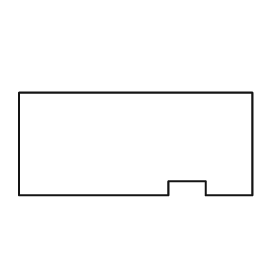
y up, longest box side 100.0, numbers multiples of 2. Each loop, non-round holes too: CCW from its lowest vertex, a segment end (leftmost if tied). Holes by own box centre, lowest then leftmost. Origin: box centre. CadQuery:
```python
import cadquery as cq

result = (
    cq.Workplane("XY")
    .moveTo(-50.0, -22.0)
    .lineTo(14.0, -22.0)
    .lineTo(14.0, -16.0)
    .lineTo(30.0, -16.0)
    .lineTo(30.0, -22.0)
    .lineTo(50.0, -22.0)
    .lineTo(50.0, 22.0)
    .lineTo(-50.0, 22.0)
    .close()
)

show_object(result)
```